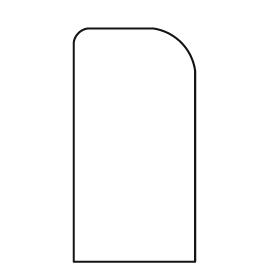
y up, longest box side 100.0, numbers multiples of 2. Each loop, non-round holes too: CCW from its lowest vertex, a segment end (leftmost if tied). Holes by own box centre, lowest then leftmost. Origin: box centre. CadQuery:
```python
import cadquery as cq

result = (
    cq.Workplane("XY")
    .moveTo(-26.0, -50.0)
    .lineTo(26.0, -50.0)
    .lineTo(26.0, 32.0)
    .threePointArc((20.0, 44.0), (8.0, 50.0))
    .lineTo(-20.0, 50.0)
    .threePointArc((-24.0, 48.0), (-26.0, 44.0))
    .close()
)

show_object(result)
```